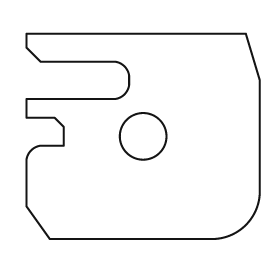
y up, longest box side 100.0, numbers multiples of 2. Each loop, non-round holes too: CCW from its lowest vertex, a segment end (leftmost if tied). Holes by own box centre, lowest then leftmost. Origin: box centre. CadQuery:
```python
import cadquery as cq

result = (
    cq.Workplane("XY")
    .moveTo(-40.0, -44.0)
    .lineTo(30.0, -44.0)
    .threePointArc((44.0, -38.0), (50.0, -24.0))
    .lineTo(50.0, 24.0)
    .lineTo(44.0, 44.0)
    .lineTo(-50.0, 44.0)
    .lineTo(-50.0, 38.0)
    .lineTo(-44.0, 32.0)
    .lineTo(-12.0, 32.0)
    .threePointArc((-8.0, 30.0), (-6.0, 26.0))
    .lineTo(-6.0, 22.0)
    .threePointArc((-8.0, 18.0), (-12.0, 16.0))
    .lineTo(-50.0, 16.0)
    .lineTo(-50.0, 8.0)
    .lineTo(-38.0, 8.0)
    .lineTo(-34.0, 4.0)
    .lineTo(-34.0, -4.0)
    .lineTo(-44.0, -4.0)
    .threePointArc((-48.0, -6.0), (-50.0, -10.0))
    .lineTo(-50.0, -30.0)
    .close()
    .moveTo(0.0, 0.0)
    .circle(10.0)
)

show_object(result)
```